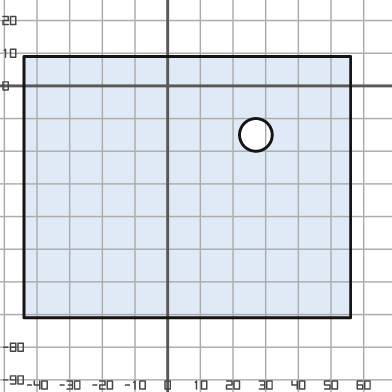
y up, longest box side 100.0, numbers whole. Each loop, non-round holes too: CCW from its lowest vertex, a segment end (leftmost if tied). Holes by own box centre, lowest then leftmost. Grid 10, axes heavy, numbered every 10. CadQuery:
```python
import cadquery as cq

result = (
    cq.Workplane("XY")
    .moveTo(-44.0, -71.0)
    .lineTo(56.0, -71.0)
    .lineTo(56.0, 9.0)
    .lineTo(-44.0, 9.0)
    .close()
    .moveTo(27.0, -15.0)
    .circle(5.0)
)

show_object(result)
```